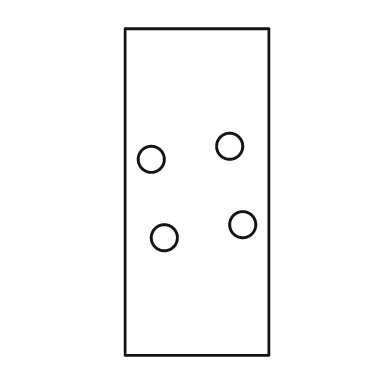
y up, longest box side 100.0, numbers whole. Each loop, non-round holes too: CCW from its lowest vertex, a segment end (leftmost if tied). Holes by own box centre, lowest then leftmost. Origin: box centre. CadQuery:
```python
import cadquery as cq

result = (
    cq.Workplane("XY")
    .moveTo(-22.0, -50.0)
    .lineTo(22.0, -50.0)
    .lineTo(22.0, 50.0)
    .lineTo(-22.0, 50.0)
    .close()
    .moveTo(-10.0, -14.0)
    .circle(4.0)
    .moveTo(14.0, -10.0)
    .circle(4.0)
    .moveTo(-14.0, 10.0)
    .circle(4.0)
    .moveTo(10.0, 14.0)
    .circle(4.0)
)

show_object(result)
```